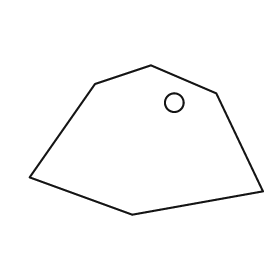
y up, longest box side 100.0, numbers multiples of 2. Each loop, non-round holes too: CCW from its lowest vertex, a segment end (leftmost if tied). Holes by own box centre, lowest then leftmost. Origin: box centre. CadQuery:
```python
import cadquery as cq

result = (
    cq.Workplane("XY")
    .moveTo(-6.0, -32.0)
    .lineTo(50.0, -22.0)
    .lineTo(30.0, 20.0)
    .lineTo(2.0, 32.0)
    .lineTo(-22.0, 24.0)
    .lineTo(-50.0, -16.0)
    .close()
    .moveTo(12.0, 16.0)
    .circle(4.0)
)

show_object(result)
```